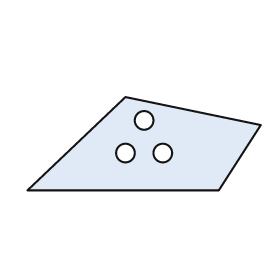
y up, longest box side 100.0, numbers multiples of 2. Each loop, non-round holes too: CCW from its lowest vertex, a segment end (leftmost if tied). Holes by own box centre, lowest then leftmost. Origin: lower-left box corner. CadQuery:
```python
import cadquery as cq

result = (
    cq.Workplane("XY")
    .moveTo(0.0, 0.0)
    .lineTo(82.0, 0.0)
    .lineTo(100.0, 28.0)
    .lineTo(42.0, 40.0)
    .close()
    .moveTo(42.0, 16.0)
    .circle(4.0)
    .moveTo(58.0, 16.0)
    .circle(4.0)
    .moveTo(50.0, 30.0)
    .circle(4.0)
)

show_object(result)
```